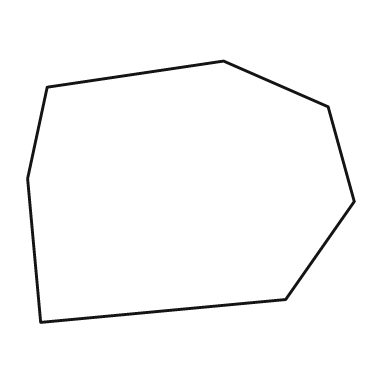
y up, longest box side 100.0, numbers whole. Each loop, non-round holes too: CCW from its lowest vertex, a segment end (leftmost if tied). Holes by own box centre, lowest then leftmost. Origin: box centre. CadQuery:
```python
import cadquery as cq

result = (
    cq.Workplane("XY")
    .moveTo(-46.0, -40.0)
    .lineTo(29.0, -33.0)
    .lineTo(50.0, -3.0)
    .lineTo(42.0, 26.0)
    .lineTo(10.0, 40.0)
    .lineTo(-44.0, 32.0)
    .lineTo(-50.0, 4.0)
    .close()
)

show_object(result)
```